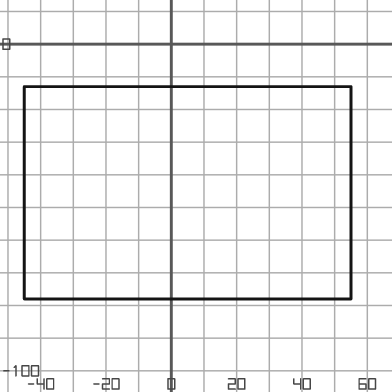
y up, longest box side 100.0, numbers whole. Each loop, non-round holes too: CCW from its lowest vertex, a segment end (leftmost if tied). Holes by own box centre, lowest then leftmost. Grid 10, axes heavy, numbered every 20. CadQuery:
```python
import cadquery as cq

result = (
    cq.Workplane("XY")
    .moveTo(-45.0, -78.0)
    .lineTo(55.0, -78.0)
    .lineTo(55.0, -13.0)
    .lineTo(-45.0, -13.0)
    .close()
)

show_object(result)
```